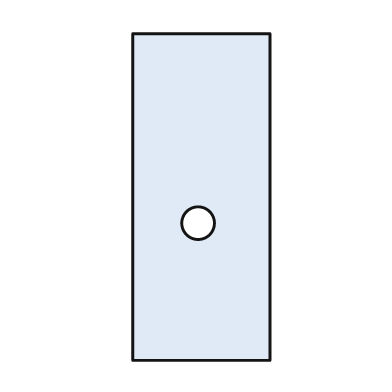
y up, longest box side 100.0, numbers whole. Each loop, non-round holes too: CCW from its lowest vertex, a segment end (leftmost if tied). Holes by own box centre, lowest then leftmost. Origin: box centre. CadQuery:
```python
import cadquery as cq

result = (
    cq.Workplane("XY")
    .moveTo(-21.0, -50.0)
    .lineTo(21.0, -50.0)
    .lineTo(21.0, 50.0)
    .lineTo(-21.0, 50.0)
    .close()
    .moveTo(-1.0, -8.0)
    .circle(5.0)
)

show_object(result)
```